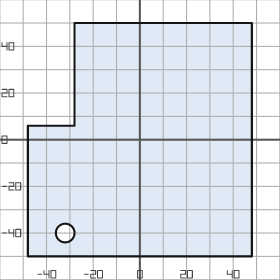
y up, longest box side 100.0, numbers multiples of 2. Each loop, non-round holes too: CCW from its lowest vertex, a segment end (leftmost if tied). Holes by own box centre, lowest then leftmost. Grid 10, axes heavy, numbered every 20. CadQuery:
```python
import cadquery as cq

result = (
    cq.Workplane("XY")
    .moveTo(-48.0, -50.0)
    .lineTo(48.0, -50.0)
    .lineTo(48.0, 50.0)
    .lineTo(-28.0, 50.0)
    .lineTo(-28.0, 6.0)
    .lineTo(-48.0, 6.0)
    .close()
    .moveTo(-32.0, -40.0)
    .circle(4.0)
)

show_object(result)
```